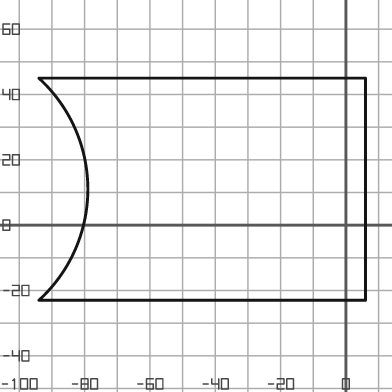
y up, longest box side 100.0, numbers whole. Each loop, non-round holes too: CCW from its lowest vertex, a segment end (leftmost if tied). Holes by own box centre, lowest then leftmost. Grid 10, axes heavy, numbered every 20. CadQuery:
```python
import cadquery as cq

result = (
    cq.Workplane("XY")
    .moveTo(-94.0, -23.0)
    .lineTo(6.0, -23.0)
    .lineTo(6.0, 45.0)
    .lineTo(-94.0, 45.0)
    .threePointArc((-79.0, 11.0), (-94.0, -23.0))
    .close()
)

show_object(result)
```